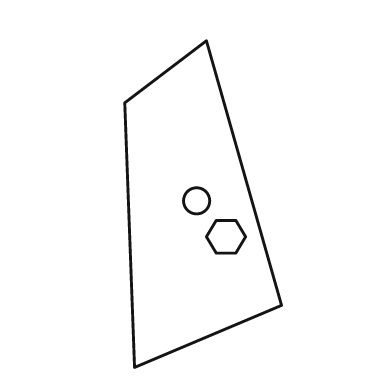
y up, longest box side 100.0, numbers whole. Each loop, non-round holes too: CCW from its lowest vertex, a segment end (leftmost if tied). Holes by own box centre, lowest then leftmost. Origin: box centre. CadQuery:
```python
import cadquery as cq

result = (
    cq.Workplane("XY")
    .moveTo(-21.0, -50.0)
    .lineTo(24.0, -31.0)
    .lineTo(1.0, 50.0)
    .lineTo(-24.0, 31.0)
    .close()
    .moveTo(4.0, -15.0)
    .lineTo(10.0, -15.0)
    .lineTo(13.0, -10.0)
    .lineTo(10.0, -5.0)
    .lineTo(4.0, -5.0)
    .lineTo(1.0, -10.0)
    .close()
    .moveTo(-2.0, 1.0)
    .circle(4.0)
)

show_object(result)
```